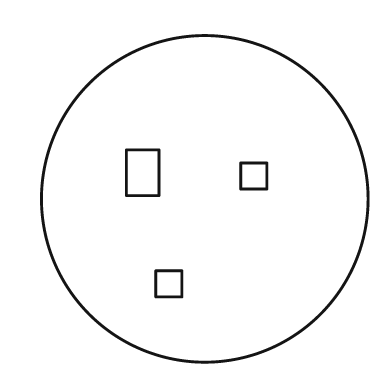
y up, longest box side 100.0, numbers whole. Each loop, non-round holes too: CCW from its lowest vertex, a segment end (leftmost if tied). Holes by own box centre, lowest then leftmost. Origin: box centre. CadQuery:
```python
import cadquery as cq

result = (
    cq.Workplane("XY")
    .moveTo(0.0, 0.0)
    .circle(50.0)
    .moveTo(-15.0, -30.0)
    .lineTo(-7.0, -30.0)
    .lineTo(-7.0, -22.0)
    .lineTo(-15.0, -22.0)
    .close()
    .moveTo(11.0, 3.0)
    .lineTo(19.0, 3.0)
    .lineTo(19.0, 11.0)
    .lineTo(11.0, 11.0)
    .close()
    .moveTo(-24.0, 1.0)
    .lineTo(-14.0, 1.0)
    .lineTo(-14.0, 15.0)
    .lineTo(-24.0, 15.0)
    .close()
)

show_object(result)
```